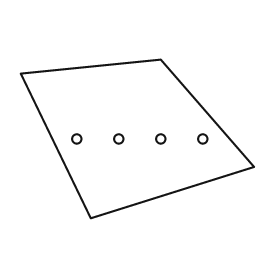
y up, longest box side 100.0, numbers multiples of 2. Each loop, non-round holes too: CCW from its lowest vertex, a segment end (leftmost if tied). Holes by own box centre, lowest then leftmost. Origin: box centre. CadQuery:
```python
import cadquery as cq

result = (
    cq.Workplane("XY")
    .moveTo(-20.0, -34.0)
    .lineTo(50.0, -12.0)
    .lineTo(10.0, 34.0)
    .lineTo(-50.0, 28.0)
    .close()
    .moveTo(-26.0, 0.0)
    .circle(2.0)
    .moveTo(-8.0, 0.0)
    .circle(2.0)
    .moveTo(10.0, 0.0)
    .circle(2.0)
    .moveTo(28.0, 0.0)
    .circle(2.0)
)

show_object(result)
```